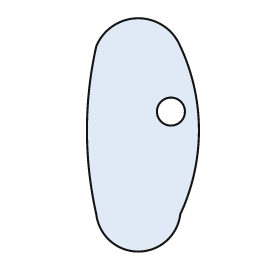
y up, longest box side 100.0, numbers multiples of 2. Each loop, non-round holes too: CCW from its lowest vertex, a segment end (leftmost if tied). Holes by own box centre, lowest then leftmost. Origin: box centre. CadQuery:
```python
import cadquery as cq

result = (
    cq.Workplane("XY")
    .moveTo(-20.0, -34.0)
    .threePointArc((-2.0, -50.0), (16.0, -34.0))
    .threePointArc((24.0, 2.0), (16.0, 38.0))
    .threePointArc((-2.0, 50.0), (-20.0, 38.0))
    .threePointArc((-24.0, 2.0), (-20.0, -34.0))
    .close()
    .moveTo(12.0, 10.0)
    .circle(6.0)
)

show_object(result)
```